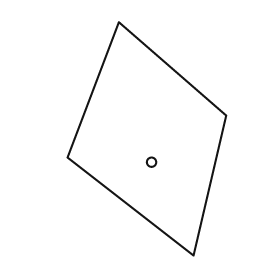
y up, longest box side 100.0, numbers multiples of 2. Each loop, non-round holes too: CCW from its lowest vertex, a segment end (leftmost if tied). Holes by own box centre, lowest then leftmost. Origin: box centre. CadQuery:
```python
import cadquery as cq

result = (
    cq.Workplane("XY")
    .moveTo(20.0, -50.0)
    .lineTo(34.0, 10.0)
    .lineTo(-12.0, 50.0)
    .lineTo(-34.0, -8.0)
    .close()
    .moveTo(2.0, -10.0)
    .circle(2.0)
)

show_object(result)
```